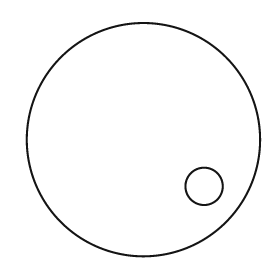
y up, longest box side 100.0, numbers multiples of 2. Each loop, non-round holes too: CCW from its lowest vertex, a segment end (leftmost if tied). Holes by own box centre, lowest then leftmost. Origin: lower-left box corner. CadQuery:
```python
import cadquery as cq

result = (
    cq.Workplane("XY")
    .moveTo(50.0, 50.0)
    .circle(50.0)
    .moveTo(76.0, 30.0)
    .circle(8.0)
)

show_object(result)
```